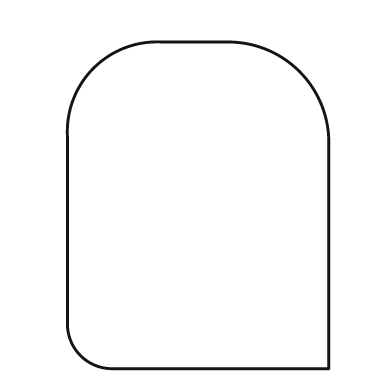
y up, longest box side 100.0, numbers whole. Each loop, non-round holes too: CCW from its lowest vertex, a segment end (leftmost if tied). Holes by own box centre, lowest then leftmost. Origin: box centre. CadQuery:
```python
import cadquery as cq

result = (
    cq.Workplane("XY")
    .moveTo(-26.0, -50.0)
    .lineTo(40.0, -50.0)
    .lineTo(40.0, 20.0)
    .threePointArc((31.0, 41.0), (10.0, 50.0))
    .lineTo(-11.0, 50.0)
    .threePointArc((-32.0, 42.0), (-40.0, 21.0))
    .lineTo(-40.0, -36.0)
    .threePointArc((-36.0, -46.0), (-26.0, -50.0))
    .close()
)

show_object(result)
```